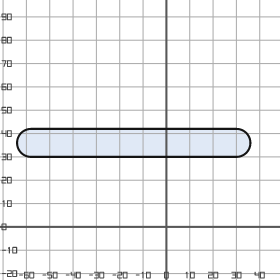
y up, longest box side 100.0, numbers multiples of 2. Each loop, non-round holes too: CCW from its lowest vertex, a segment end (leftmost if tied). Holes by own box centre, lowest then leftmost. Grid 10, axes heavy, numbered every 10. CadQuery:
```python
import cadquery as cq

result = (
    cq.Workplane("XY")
    .moveTo(-58.0, 30.0)
    .lineTo(30.0, 30.0)
    .threePointArc((36.0, 36.0), (30.0, 42.0))
    .lineTo(-58.0, 42.0)
    .threePointArc((-64.0, 36.0), (-58.0, 30.0))
    .close()
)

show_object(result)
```